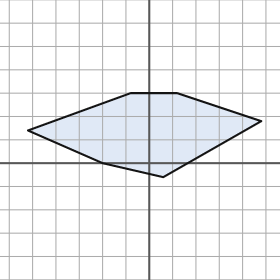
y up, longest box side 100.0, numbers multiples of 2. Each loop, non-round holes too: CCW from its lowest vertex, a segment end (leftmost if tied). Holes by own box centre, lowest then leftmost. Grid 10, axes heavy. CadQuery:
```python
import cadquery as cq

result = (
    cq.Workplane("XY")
    .moveTo(6.0, -6.0)
    .lineTo(48.0, 18.0)
    .lineTo(12.0, 30.0)
    .lineTo(-8.0, 30.0)
    .lineTo(-52.0, 14.0)
    .lineTo(-20.0, 0.0)
    .close()
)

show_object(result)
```